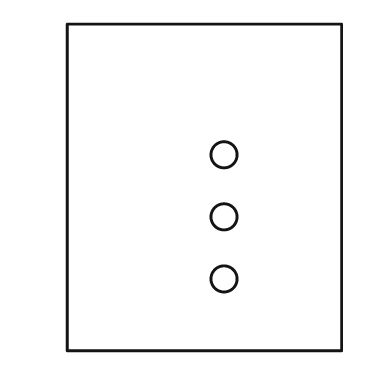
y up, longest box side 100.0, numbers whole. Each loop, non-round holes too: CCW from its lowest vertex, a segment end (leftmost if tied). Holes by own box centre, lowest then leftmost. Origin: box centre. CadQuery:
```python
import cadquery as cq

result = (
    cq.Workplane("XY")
    .moveTo(-42.0, -50.0)
    .lineTo(42.0, -50.0)
    .lineTo(42.0, 50.0)
    .lineTo(-42.0, 50.0)
    .close()
    .moveTo(6.0, -28.0)
    .circle(4.0)
    .moveTo(6.0, -9.0)
    .circle(4.0)
    .moveTo(6.0, 10.0)
    .circle(4.0)
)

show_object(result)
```